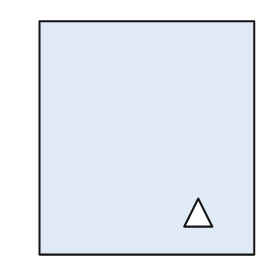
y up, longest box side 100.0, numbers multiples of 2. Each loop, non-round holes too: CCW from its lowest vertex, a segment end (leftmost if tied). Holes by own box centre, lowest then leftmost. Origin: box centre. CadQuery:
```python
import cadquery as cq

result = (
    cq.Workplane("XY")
    .moveTo(-46.0, -50.0)
    .lineTo(46.0, -50.0)
    .lineTo(46.0, 50.0)
    .lineTo(-46.0, 50.0)
    .close()
    .moveTo(16.0, -38.0)
    .lineTo(28.0, -38.0)
    .lineTo(22.0, -26.0)
    .close()
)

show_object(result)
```